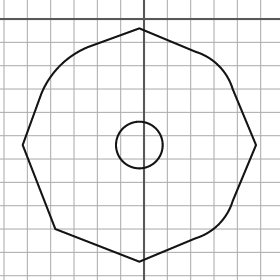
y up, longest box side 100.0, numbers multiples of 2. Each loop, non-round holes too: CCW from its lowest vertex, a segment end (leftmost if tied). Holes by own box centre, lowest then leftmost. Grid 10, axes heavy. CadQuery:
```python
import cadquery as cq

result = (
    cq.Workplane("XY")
    .moveTo(-2.0, -104.0)
    .lineTo(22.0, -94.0)
    .threePointArc((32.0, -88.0), (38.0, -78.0))
    .lineTo(48.0, -54.0)
    .lineTo(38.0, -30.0)
    .threePointArc((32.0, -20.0), (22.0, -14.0))
    .lineTo(-2.0, -4.0)
    .lineTo(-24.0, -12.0)
    .threePointArc((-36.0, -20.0), (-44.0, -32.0))
    .lineTo(-52.0, -54.0)
    .lineTo(-38.0, -90.0)
    .close()
    .moveTo(-2.0, -54.0)
    .circle(10.0)
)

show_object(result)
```